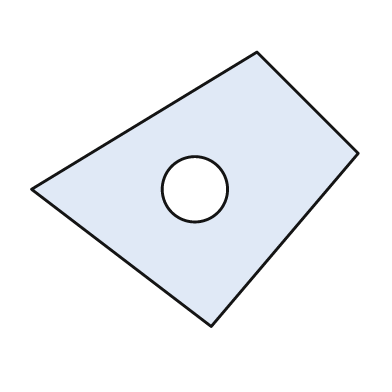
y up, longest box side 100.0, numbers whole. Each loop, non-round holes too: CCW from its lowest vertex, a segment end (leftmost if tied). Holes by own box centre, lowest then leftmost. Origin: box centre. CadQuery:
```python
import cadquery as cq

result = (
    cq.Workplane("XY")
    .moveTo(5.0, -42.0)
    .lineTo(50.0, 11.0)
    .lineTo(19.0, 42.0)
    .lineTo(-50.0, 0.0)
    .close()
    .moveTo(0.0, 0.0)
    .circle(10.0)
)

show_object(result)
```